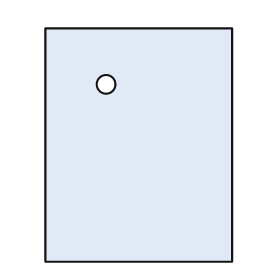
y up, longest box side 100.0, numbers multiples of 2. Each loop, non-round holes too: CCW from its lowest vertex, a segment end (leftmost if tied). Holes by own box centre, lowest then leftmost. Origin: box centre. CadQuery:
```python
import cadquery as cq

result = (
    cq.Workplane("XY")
    .moveTo(-40.0, -50.0)
    .lineTo(40.0, -50.0)
    .lineTo(40.0, 50.0)
    .lineTo(-40.0, 50.0)
    .close()
    .moveTo(-14.0, 26.0)
    .circle(4.0)
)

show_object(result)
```